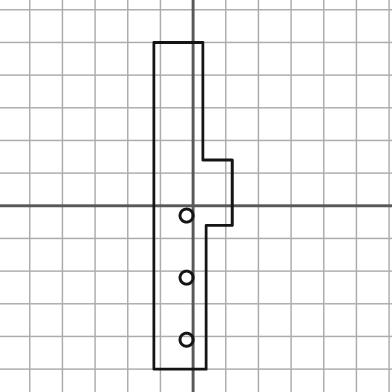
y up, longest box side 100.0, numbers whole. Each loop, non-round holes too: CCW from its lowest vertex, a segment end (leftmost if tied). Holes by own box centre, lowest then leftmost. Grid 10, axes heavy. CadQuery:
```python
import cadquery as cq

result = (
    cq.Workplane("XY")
    .moveTo(-12.0, -50.0)
    .lineTo(4.0, -50.0)
    .lineTo(4.0, -6.0)
    .lineTo(12.0, -6.0)
    .lineTo(12.0, 14.0)
    .lineTo(3.0, 14.0)
    .lineTo(3.0, 50.0)
    .lineTo(-12.0, 50.0)
    .close()
    .moveTo(-2.0, -41.0)
    .circle(2.0)
    .moveTo(-2.0, -22.0)
    .circle(2.0)
    .moveTo(-2.0, -3.0)
    .circle(2.0)
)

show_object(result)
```